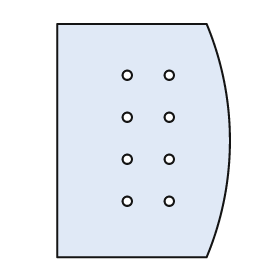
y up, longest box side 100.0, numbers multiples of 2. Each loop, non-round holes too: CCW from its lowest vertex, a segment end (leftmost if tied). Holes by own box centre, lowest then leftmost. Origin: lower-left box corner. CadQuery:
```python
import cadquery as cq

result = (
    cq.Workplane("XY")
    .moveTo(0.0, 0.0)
    .lineTo(64.0, 0.0)
    .threePointArc((74.0, 50.0), (64.0, 100.0))
    .lineTo(0.0, 100.0)
    .close()
    .moveTo(30.0, 24.0)
    .circle(2.0)
    .moveTo(48.0, 24.0)
    .circle(2.0)
    .moveTo(30.0, 42.0)
    .circle(2.0)
    .moveTo(48.0, 42.0)
    .circle(2.0)
    .moveTo(30.0, 60.0)
    .circle(2.0)
    .moveTo(48.0, 60.0)
    .circle(2.0)
    .moveTo(30.0, 78.0)
    .circle(2.0)
    .moveTo(48.0, 78.0)
    .circle(2.0)
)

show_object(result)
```